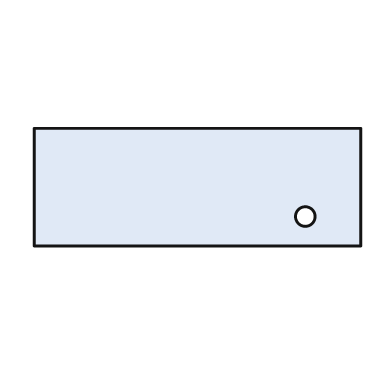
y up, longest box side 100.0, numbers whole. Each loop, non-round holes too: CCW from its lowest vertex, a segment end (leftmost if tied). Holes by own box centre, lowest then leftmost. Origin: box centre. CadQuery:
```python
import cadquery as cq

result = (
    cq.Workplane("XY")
    .moveTo(-50.0, -18.0)
    .lineTo(50.0, -18.0)
    .lineTo(50.0, 18.0)
    .lineTo(-50.0, 18.0)
    .close()
    .moveTo(33.0, -9.0)
    .circle(3.0)
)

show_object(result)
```